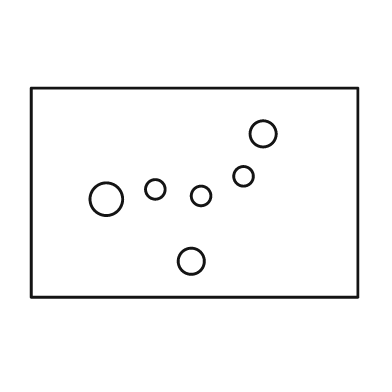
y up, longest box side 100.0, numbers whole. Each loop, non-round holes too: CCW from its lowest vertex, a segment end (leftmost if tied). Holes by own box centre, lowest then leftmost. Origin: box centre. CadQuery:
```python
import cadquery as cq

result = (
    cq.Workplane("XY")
    .moveTo(-50.0, -32.0)
    .lineTo(50.0, -32.0)
    .lineTo(50.0, 32.0)
    .lineTo(-50.0, 32.0)
    .close()
    .moveTo(-1.0, -21.0)
    .circle(4.0)
    .moveTo(-27.0, -2.0)
    .circle(5.0)
    .moveTo(2.0, -1.0)
    .circle(3.0)
    .moveTo(-12.0, 1.0)
    .circle(3.0)
    .moveTo(15.0, 5.0)
    .circle(3.0)
    .moveTo(21.0, 18.0)
    .circle(4.0)
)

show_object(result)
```